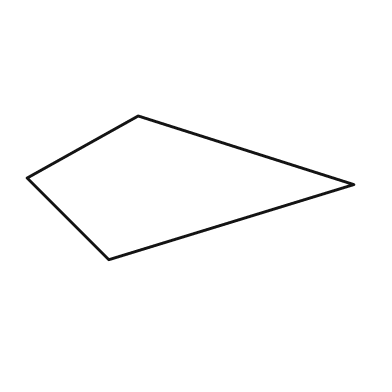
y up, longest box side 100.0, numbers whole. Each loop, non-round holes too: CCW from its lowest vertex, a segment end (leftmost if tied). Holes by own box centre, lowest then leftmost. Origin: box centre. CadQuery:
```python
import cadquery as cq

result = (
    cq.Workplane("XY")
    .moveTo(-25.0, -22.0)
    .lineTo(50.0, 1.0)
    .lineTo(-16.0, 22.0)
    .lineTo(-50.0, 3.0)
    .close()
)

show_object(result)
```